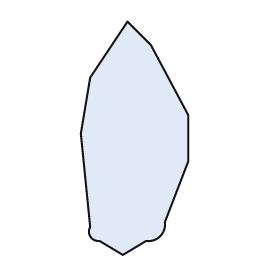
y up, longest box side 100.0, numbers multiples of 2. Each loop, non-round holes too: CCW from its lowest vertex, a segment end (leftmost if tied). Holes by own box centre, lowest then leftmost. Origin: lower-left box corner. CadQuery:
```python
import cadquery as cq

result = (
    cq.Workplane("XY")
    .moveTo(18.0, 0.0)
    .lineTo(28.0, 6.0)
    .threePointArc((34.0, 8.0), (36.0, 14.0))
    .lineTo(46.0, 40.0)
    .lineTo(46.0, 60.0)
    .lineTo(30.0, 90.0)
    .lineTo(20.0, 100.0)
    .lineTo(4.0, 76.0)
    .lineTo(0.0, 52.0)
    .lineTo(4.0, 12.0)
    .threePointArc((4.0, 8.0), (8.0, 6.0))
    .close()
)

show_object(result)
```